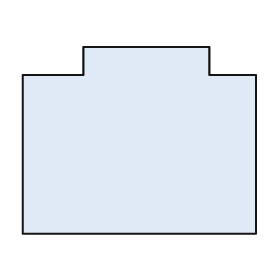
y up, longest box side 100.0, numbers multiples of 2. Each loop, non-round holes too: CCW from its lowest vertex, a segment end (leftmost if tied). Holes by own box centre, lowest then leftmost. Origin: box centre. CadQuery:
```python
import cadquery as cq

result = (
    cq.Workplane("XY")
    .moveTo(-50.0, -40.0)
    .lineTo(50.0, -40.0)
    .lineTo(50.0, 28.0)
    .lineTo(30.0, 28.0)
    .lineTo(30.0, 40.0)
    .lineTo(-24.0, 40.0)
    .lineTo(-24.0, 28.0)
    .lineTo(-50.0, 28.0)
    .close()
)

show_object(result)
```